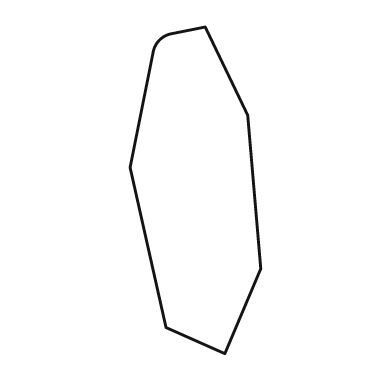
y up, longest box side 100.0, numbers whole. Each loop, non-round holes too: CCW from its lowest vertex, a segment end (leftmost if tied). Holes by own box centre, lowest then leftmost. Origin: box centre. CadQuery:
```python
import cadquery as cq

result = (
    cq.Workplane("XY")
    .moveTo(9.0, -50.0)
    .lineTo(20.0, -24.0)
    .lineTo(16.0, 23.0)
    .lineTo(3.0, 50.0)
    .lineTo(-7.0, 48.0)
    .threePointArc((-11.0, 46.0), (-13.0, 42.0))
    .lineTo(-20.0, 7.0)
    .lineTo(-9.0, -42.0)
    .close()
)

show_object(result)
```